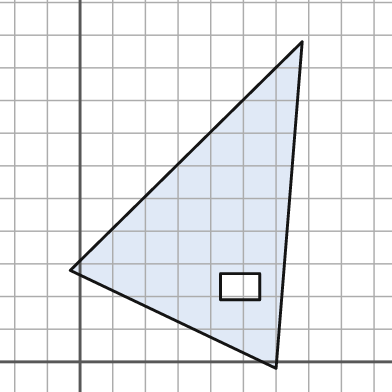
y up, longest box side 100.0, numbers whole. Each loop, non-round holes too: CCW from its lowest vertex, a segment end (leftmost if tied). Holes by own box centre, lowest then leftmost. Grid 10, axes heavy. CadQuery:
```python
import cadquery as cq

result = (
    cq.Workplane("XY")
    .moveTo(60.0, -2.0)
    .lineTo(68.0, 98.0)
    .lineTo(-3.0, 28.0)
    .close()
    .moveTo(43.0, 19.0)
    .lineTo(55.0, 19.0)
    .lineTo(55.0, 27.0)
    .lineTo(43.0, 27.0)
    .close()
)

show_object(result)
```